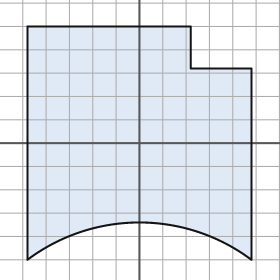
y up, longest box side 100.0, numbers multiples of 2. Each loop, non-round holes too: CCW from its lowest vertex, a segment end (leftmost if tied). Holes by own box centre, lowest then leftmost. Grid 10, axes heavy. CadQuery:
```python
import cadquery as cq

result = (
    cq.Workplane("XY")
    .moveTo(-48.0, -50.0)
    .threePointArc((0.0, -34.0), (48.0, -50.0))
    .lineTo(48.0, 32.0)
    .lineTo(22.0, 32.0)
    .lineTo(22.0, 50.0)
    .lineTo(-48.0, 50.0)
    .close()
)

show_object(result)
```